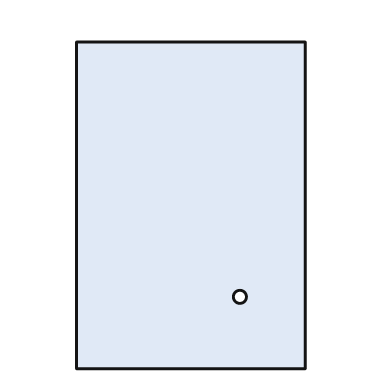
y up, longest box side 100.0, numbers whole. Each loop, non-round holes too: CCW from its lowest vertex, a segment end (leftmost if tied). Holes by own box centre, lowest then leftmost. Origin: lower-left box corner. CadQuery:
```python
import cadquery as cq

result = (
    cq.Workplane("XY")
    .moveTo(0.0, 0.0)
    .lineTo(70.0, 0.0)
    .lineTo(70.0, 100.0)
    .lineTo(0.0, 100.0)
    .close()
    .moveTo(50.0, 22.0)
    .circle(2.0)
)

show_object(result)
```